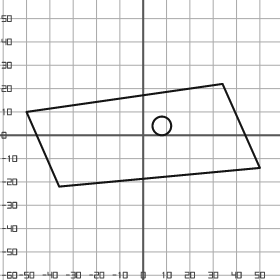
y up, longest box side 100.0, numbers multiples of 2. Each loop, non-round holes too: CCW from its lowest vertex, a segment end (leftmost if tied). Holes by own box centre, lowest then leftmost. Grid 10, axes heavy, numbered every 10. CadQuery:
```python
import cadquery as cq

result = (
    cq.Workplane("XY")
    .moveTo(-36.0, -22.0)
    .lineTo(50.0, -14.0)
    .lineTo(34.0, 22.0)
    .lineTo(-50.0, 10.0)
    .close()
    .moveTo(8.0, 4.0)
    .circle(4.0)
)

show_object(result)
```